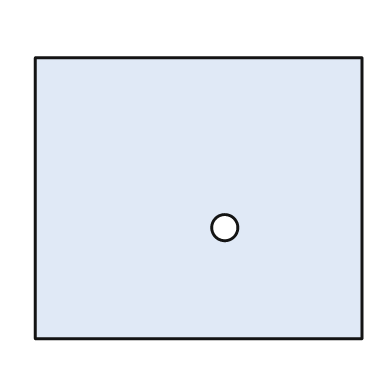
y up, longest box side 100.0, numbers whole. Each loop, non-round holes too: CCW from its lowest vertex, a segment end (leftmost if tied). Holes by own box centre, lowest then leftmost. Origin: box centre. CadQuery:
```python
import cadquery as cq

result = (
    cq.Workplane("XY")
    .moveTo(-50.0, -43.0)
    .lineTo(50.0, -43.0)
    .lineTo(50.0, 43.0)
    .lineTo(-50.0, 43.0)
    .close()
    .moveTo(8.0, -9.0)
    .circle(4.0)
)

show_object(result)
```